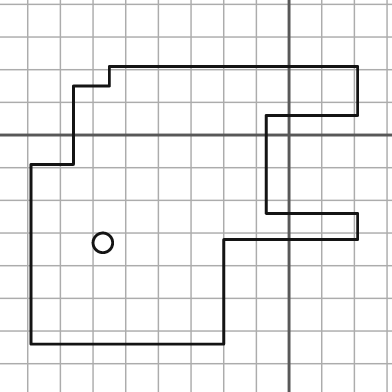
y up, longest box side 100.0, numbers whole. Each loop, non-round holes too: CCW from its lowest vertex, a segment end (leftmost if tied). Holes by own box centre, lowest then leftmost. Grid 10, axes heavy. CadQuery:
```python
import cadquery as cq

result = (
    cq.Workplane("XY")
    .moveTo(-79.0, -64.0)
    .lineTo(-20.0, -64.0)
    .lineTo(-20.0, -32.0)
    .lineTo(21.0, -32.0)
    .lineTo(21.0, -24.0)
    .lineTo(-7.0, -24.0)
    .lineTo(-7.0, 6.0)
    .lineTo(21.0, 6.0)
    .lineTo(21.0, 21.0)
    .lineTo(-55.0, 21.0)
    .lineTo(-55.0, 15.0)
    .lineTo(-66.0, 15.0)
    .lineTo(-66.0, -9.0)
    .lineTo(-79.0, -9.0)
    .close()
    .moveTo(-57.0, -33.0)
    .circle(3.0)
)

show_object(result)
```